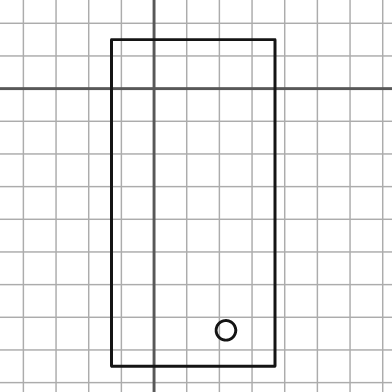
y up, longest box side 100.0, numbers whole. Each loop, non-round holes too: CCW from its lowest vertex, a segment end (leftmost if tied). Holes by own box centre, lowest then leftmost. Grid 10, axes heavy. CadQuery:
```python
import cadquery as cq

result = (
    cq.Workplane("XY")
    .moveTo(-13.0, -85.0)
    .lineTo(37.0, -85.0)
    .lineTo(37.0, 15.0)
    .lineTo(-13.0, 15.0)
    .close()
    .moveTo(22.0, -74.0)
    .circle(3.0)
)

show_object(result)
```